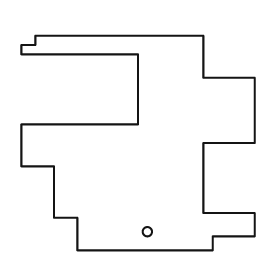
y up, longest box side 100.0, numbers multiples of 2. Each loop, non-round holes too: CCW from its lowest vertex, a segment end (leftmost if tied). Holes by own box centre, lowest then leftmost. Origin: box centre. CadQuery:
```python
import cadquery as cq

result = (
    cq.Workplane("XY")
    .moveTo(-26.0, -46.0)
    .lineTo(32.0, -46.0)
    .lineTo(32.0, -40.0)
    .lineTo(50.0, -40.0)
    .lineTo(50.0, -30.0)
    .lineTo(28.0, -30.0)
    .lineTo(28.0, 0.0)
    .lineTo(50.0, 0.0)
    .lineTo(50.0, 28.0)
    .lineTo(28.0, 28.0)
    .lineTo(28.0, 46.0)
    .lineTo(-44.0, 46.0)
    .lineTo(-44.0, 42.0)
    .lineTo(-50.0, 42.0)
    .lineTo(-50.0, 38.0)
    .lineTo(0.0, 38.0)
    .lineTo(0.0, 8.0)
    .lineTo(-50.0, 8.0)
    .lineTo(-50.0, -10.0)
    .lineTo(-36.0, -10.0)
    .lineTo(-36.0, -32.0)
    .lineTo(-26.0, -32.0)
    .close()
    .moveTo(4.0, -38.0)
    .circle(2.0)
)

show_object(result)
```